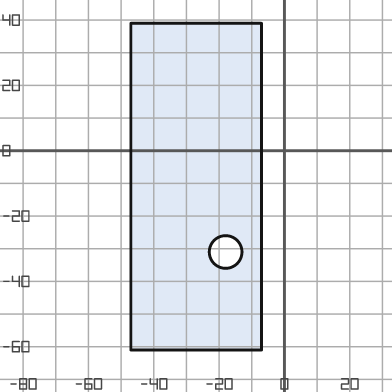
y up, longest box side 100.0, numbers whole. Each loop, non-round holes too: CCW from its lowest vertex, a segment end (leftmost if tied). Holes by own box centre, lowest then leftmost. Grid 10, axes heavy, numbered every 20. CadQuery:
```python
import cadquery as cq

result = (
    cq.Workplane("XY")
    .moveTo(-47.0, -61.0)
    .lineTo(-7.0, -61.0)
    .lineTo(-7.0, 39.0)
    .lineTo(-47.0, 39.0)
    .close()
    .moveTo(-18.0, -31.0)
    .circle(5.0)
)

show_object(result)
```